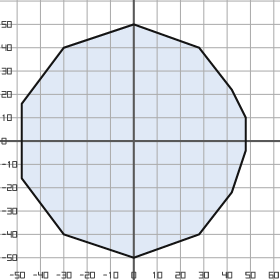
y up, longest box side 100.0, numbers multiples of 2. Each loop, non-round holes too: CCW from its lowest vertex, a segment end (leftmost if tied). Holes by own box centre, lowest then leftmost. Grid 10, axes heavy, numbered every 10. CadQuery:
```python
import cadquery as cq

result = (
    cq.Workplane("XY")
    .moveTo(0.0, -50.0)
    .lineTo(28.0, -40.0)
    .lineTo(42.0, -22.0)
    .lineTo(48.0, -4.0)
    .lineTo(48.0, 10.0)
    .lineTo(42.0, 22.0)
    .lineTo(28.0, 40.0)
    .lineTo(0.0, 50.0)
    .lineTo(-30.0, 40.0)
    .lineTo(-48.0, 16.0)
    .lineTo(-48.0, -16.0)
    .lineTo(-30.0, -40.0)
    .close()
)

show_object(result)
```